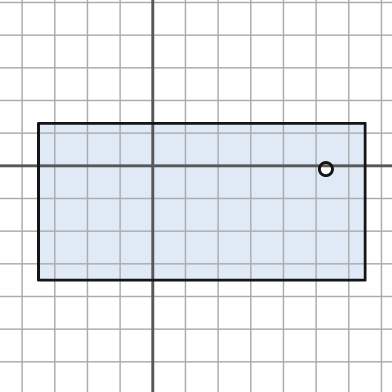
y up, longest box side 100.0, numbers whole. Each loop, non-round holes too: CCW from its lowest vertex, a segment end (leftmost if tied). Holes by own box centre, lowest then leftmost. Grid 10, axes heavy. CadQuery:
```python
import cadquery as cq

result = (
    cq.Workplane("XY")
    .moveTo(-35.0, -35.0)
    .lineTo(65.0, -35.0)
    .lineTo(65.0, 13.0)
    .lineTo(-35.0, 13.0)
    .close()
    .moveTo(53.0, -1.0)
    .circle(2.0)
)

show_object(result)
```